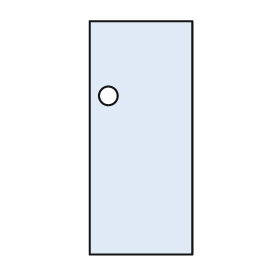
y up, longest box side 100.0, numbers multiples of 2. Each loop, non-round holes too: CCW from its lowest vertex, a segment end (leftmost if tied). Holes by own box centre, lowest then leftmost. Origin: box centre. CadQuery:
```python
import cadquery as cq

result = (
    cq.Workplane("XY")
    .moveTo(-22.0, -50.0)
    .lineTo(22.0, -50.0)
    .lineTo(22.0, 50.0)
    .lineTo(-22.0, 50.0)
    .close()
    .moveTo(-14.0, 18.0)
    .circle(4.0)
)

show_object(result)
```